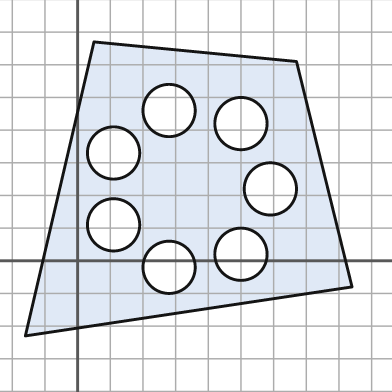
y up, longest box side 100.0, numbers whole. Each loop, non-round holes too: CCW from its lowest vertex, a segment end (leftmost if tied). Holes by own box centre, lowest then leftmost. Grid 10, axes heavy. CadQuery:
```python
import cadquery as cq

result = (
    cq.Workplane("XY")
    .moveTo(-16.0, -23.0)
    .lineTo(84.0, -8.0)
    .lineTo(67.0, 61.0)
    .lineTo(5.0, 67.0)
    .close()
    .moveTo(28.0, -2.0)
    .circle(8.0)
    .moveTo(50.0, 2.0)
    .circle(8.0)
    .moveTo(11.0, 11.0)
    .circle(8.0)
    .moveTo(59.0, 22.0)
    .circle(8.0)
    .moveTo(11.0, 33.0)
    .circle(8.0)
    .moveTo(50.0, 42.0)
    .circle(8.0)
    .moveTo(28.0, 46.0)
    .circle(8.0)
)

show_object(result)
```